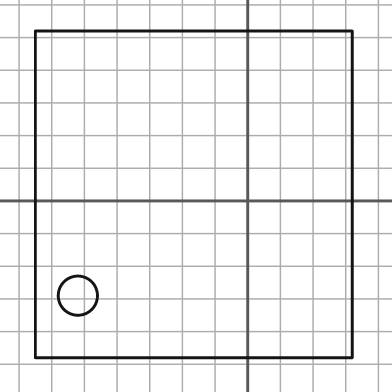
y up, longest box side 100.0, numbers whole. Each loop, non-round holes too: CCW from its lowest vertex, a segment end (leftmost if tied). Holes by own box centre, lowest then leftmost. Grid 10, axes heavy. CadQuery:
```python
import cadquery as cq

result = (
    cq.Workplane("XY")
    .moveTo(-65.0, -48.0)
    .lineTo(32.0, -48.0)
    .lineTo(32.0, 52.0)
    .lineTo(-65.0, 52.0)
    .close()
    .moveTo(-52.0, -29.0)
    .circle(6.0)
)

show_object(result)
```